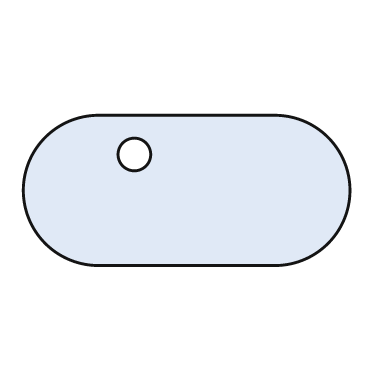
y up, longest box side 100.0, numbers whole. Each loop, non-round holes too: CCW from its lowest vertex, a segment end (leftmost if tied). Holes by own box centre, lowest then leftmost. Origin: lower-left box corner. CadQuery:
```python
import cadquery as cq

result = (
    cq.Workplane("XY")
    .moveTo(23.0, 0.0)
    .lineTo(77.0, 0.0)
    .threePointArc((100.0, 23.0), (77.0, 46.0))
    .lineTo(23.0, 46.0)
    .threePointArc((0.0, 23.0), (23.0, 0.0))
    .close()
    .moveTo(34.0, 34.0)
    .circle(5.0)
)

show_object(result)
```